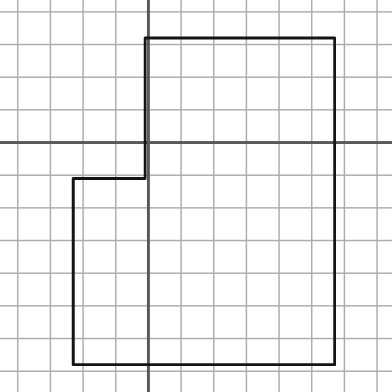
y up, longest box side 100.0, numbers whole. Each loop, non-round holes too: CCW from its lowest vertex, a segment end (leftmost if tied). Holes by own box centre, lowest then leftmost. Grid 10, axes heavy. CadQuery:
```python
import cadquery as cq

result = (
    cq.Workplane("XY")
    .moveTo(-23.0, -68.0)
    .lineTo(57.0, -68.0)
    .lineTo(57.0, 32.0)
    .lineTo(-1.0, 32.0)
    .lineTo(-1.0, -11.0)
    .lineTo(-23.0, -11.0)
    .close()
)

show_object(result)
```